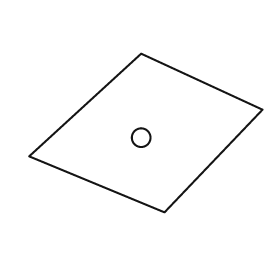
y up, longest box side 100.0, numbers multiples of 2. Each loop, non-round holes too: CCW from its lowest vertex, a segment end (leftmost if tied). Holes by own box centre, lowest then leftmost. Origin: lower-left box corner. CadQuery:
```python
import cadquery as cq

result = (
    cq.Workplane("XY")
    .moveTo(58.0, 0.0)
    .lineTo(100.0, 44.0)
    .lineTo(48.0, 68.0)
    .lineTo(0.0, 24.0)
    .close()
    .moveTo(48.0, 32.0)
    .circle(4.0)
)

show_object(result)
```